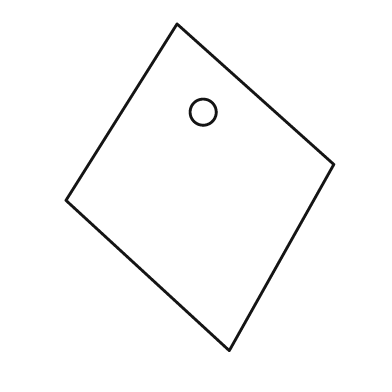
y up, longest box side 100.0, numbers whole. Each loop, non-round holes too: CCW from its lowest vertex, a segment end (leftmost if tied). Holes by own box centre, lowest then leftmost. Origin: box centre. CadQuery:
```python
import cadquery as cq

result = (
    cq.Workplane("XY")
    .moveTo(9.0, -50.0)
    .lineTo(41.0, 7.0)
    .lineTo(-7.0, 50.0)
    .lineTo(-41.0, -4.0)
    .close()
    .moveTo(1.0, 23.0)
    .circle(4.0)
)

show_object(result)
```